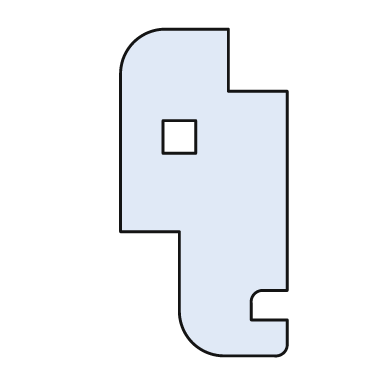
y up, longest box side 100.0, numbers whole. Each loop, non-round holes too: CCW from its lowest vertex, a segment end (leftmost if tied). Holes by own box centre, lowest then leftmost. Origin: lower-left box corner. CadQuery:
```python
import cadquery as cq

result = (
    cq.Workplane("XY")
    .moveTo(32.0, 0.0)
    .lineTo(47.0, 0.0)
    .threePointArc((50.0, 1.0), (51.0, 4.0))
    .lineTo(51.0, 11.0)
    .lineTo(40.0, 11.0)
    .lineTo(40.0, 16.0)
    .threePointArc((41.0, 19.0), (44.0, 20.0))
    .lineTo(51.0, 20.0)
    .lineTo(51.0, 81.0)
    .lineTo(33.0, 81.0)
    .lineTo(33.0, 100.0)
    .lineTo(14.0, 100.0)
    .threePointArc((4.0, 96.0), (0.0, 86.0))
    .lineTo(0.0, 38.0)
    .lineTo(18.0, 38.0)
    .lineTo(18.0, 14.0)
    .threePointArc((22.0, 4.0), (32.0, 0.0))
    .close()
    .moveTo(13.0, 62.0)
    .lineTo(23.0, 62.0)
    .lineTo(23.0, 72.0)
    .lineTo(13.0, 72.0)
    .close()
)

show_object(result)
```